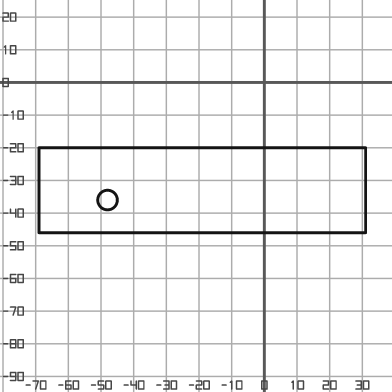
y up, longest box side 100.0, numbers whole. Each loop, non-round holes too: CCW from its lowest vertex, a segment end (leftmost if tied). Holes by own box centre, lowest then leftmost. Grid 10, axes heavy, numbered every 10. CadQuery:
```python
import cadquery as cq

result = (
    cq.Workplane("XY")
    .moveTo(-69.0, -46.0)
    .lineTo(31.0, -46.0)
    .lineTo(31.0, -20.0)
    .lineTo(-69.0, -20.0)
    .close()
    .moveTo(-48.0, -36.0)
    .circle(3.0)
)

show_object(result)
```